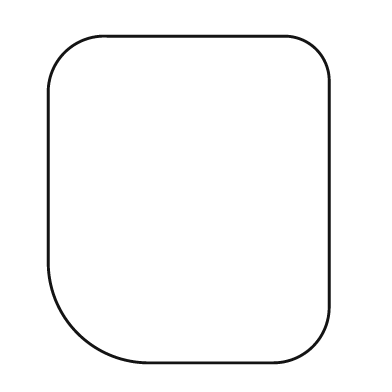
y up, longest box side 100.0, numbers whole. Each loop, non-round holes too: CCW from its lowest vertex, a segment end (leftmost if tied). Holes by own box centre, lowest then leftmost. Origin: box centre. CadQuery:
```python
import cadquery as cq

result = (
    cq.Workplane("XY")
    .moveTo(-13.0, -50.0)
    .lineTo(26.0, -50.0)
    .threePointArc((38.0, -45.0), (43.0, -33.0))
    .lineTo(43.0, 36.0)
    .threePointArc((39.0, 46.0), (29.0, 50.0))
    .lineTo(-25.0, 50.0)
    .threePointArc((-38.0, 45.0), (-43.0, 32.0))
    .lineTo(-43.0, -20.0)
    .threePointArc((-34.0, -41.0), (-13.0, -50.0))
    .close()
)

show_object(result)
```